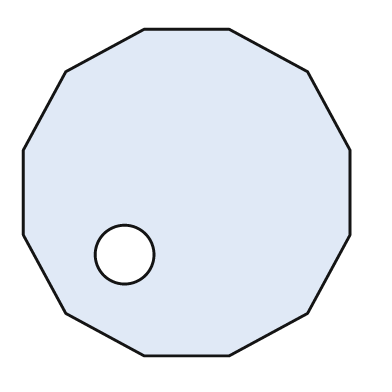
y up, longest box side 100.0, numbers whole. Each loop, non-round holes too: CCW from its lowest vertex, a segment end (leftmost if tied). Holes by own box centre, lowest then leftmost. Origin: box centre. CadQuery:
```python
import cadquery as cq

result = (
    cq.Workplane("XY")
    .moveTo(-13.0, -50.0)
    .lineTo(13.0, -50.0)
    .lineTo(37.0, -37.0)
    .lineTo(50.0, -13.0)
    .lineTo(50.0, 13.0)
    .lineTo(37.0, 37.0)
    .lineTo(13.0, 50.0)
    .lineTo(-13.0, 50.0)
    .lineTo(-37.0, 37.0)
    .lineTo(-50.0, 13.0)
    .lineTo(-50.0, -13.0)
    .lineTo(-37.0, -37.0)
    .close()
    .moveTo(-19.0, -19.0)
    .circle(9.0)
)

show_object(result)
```